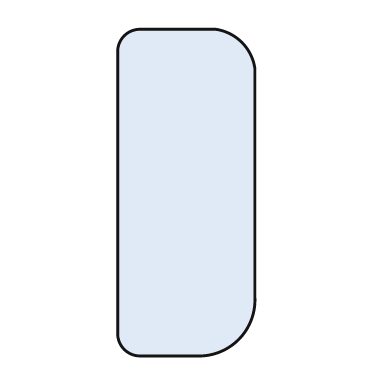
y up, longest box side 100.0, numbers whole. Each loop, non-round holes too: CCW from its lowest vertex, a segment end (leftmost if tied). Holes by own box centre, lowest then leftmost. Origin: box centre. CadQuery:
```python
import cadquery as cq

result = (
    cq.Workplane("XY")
    .moveTo(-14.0, -50.0)
    .lineTo(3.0, -50.0)
    .threePointArc((16.0, -45.0), (21.0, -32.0))
    .lineTo(21.0, 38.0)
    .threePointArc((17.0, 46.0), (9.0, 50.0))
    .lineTo(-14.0, 50.0)
    .threePointArc((-19.0, 48.0), (-21.0, 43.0))
    .lineTo(-21.0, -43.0)
    .threePointArc((-19.0, -48.0), (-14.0, -50.0))
    .close()
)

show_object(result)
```